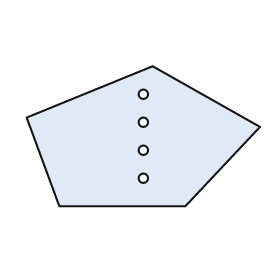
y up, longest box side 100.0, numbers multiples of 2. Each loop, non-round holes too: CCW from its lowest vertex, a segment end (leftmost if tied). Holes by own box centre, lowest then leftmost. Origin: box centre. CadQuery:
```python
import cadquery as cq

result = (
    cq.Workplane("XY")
    .moveTo(-36.0, -30.0)
    .lineTo(18.0, -30.0)
    .lineTo(50.0, 4.0)
    .lineTo(4.0, 30.0)
    .lineTo(-50.0, 8.0)
    .close()
    .moveTo(0.0, -18.0)
    .circle(2.0)
    .moveTo(0.0, -6.0)
    .circle(2.0)
    .moveTo(0.0, 6.0)
    .circle(2.0)
    .moveTo(0.0, 18.0)
    .circle(2.0)
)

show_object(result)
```